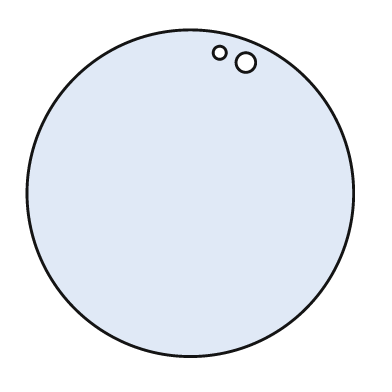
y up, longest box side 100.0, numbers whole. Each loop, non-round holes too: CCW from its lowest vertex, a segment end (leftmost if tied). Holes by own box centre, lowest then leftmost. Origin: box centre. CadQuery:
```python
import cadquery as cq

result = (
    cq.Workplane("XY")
    .moveTo(0.0, 0.0)
    .circle(50.0)
    .moveTo(17.0, 40.0)
    .circle(3.0)
    .moveTo(9.0, 43.0)
    .circle(2.0)
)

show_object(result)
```